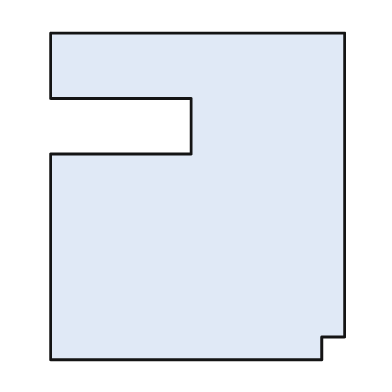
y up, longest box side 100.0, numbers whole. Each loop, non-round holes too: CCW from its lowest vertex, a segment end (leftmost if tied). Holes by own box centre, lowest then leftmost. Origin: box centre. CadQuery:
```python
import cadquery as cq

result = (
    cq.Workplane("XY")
    .moveTo(-45.0, -50.0)
    .lineTo(38.0, -50.0)
    .lineTo(38.0, -43.0)
    .lineTo(45.0, -43.0)
    .lineTo(45.0, 50.0)
    .lineTo(-45.0, 50.0)
    .lineTo(-45.0, 30.0)
    .lineTo(-2.0, 30.0)
    .lineTo(-2.0, 13.0)
    .lineTo(-45.0, 13.0)
    .close()
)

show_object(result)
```